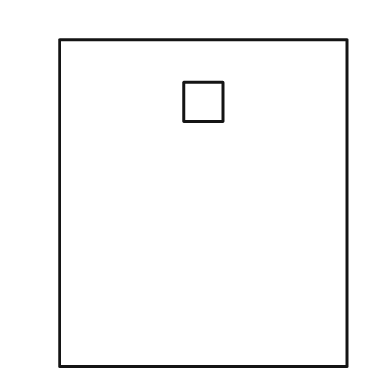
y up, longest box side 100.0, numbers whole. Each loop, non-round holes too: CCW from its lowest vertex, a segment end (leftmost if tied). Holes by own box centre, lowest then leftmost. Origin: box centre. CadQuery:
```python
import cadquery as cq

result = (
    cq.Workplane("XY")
    .moveTo(-44.0, -50.0)
    .lineTo(44.0, -50.0)
    .lineTo(44.0, 50.0)
    .lineTo(-44.0, 50.0)
    .close()
    .moveTo(-6.0, 25.0)
    .lineTo(6.0, 25.0)
    .lineTo(6.0, 37.0)
    .lineTo(-6.0, 37.0)
    .close()
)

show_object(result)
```